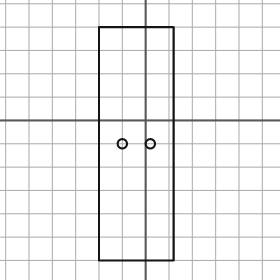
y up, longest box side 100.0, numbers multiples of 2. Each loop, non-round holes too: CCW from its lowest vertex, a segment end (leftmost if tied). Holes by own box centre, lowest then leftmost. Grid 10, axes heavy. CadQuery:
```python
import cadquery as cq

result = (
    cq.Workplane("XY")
    .moveTo(-20.0, -60.0)
    .lineTo(12.0, -60.0)
    .lineTo(12.0, 40.0)
    .lineTo(-20.0, 40.0)
    .close()
    .moveTo(-10.0, -10.0)
    .circle(2.0)
    .moveTo(2.0, -10.0)
    .circle(2.0)
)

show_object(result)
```